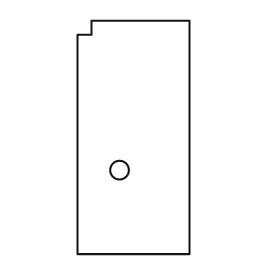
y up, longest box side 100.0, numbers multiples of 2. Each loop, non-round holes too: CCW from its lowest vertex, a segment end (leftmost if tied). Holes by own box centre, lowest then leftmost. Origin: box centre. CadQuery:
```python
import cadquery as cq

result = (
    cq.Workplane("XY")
    .moveTo(-24.0, -50.0)
    .lineTo(24.0, -50.0)
    .lineTo(24.0, 50.0)
    .lineTo(-18.0, 50.0)
    .lineTo(-18.0, 44.0)
    .lineTo(-24.0, 44.0)
    .close()
    .moveTo(-6.0, -14.0)
    .circle(4.0)
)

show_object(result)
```